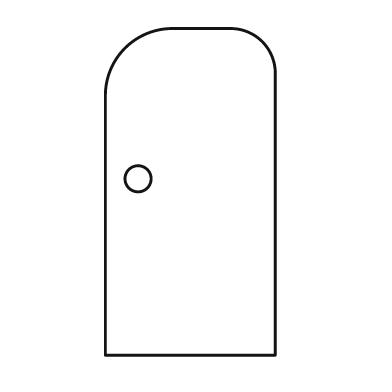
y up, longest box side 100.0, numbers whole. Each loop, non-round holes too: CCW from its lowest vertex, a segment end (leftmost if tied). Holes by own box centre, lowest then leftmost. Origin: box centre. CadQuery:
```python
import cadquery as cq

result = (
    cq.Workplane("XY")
    .moveTo(-26.0, -50.0)
    .lineTo(26.0, -50.0)
    .lineTo(26.0, 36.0)
    .threePointArc((22.0, 46.0), (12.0, 50.0))
    .lineTo(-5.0, 50.0)
    .threePointArc((-20.0, 44.0), (-26.0, 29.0))
    .close()
    .moveTo(-16.0, 4.0)
    .circle(4.0)
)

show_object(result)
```